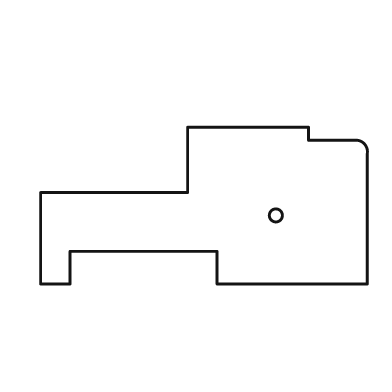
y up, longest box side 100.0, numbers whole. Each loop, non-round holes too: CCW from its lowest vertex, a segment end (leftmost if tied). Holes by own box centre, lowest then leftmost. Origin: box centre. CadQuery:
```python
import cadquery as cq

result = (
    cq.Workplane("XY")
    .moveTo(-50.0, -24.0)
    .lineTo(-41.0, -24.0)
    .lineTo(-41.0, -14.0)
    .lineTo(4.0, -14.0)
    .lineTo(4.0, -24.0)
    .lineTo(50.0, -24.0)
    .lineTo(50.0, 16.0)
    .threePointArc((49.0, 19.0), (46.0, 20.0))
    .lineTo(32.0, 20.0)
    .lineTo(32.0, 24.0)
    .lineTo(-5.0, 24.0)
    .lineTo(-5.0, 4.0)
    .lineTo(-50.0, 4.0)
    .close()
    .moveTo(22.0, -3.0)
    .circle(2.0)
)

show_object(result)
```